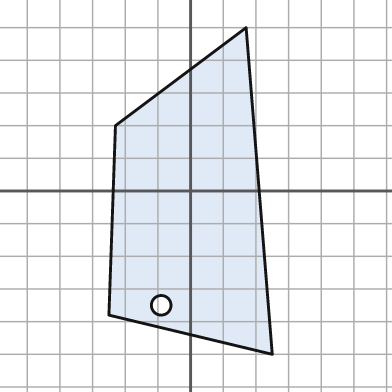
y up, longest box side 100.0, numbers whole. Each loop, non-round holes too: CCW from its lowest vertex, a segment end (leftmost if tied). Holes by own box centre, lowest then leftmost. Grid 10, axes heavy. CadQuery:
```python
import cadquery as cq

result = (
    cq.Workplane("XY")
    .moveTo(25.0, -50.0)
    .lineTo(17.0, 50.0)
    .lineTo(-23.0, 20.0)
    .lineTo(-25.0, -38.0)
    .close()
    .moveTo(-9.0, -35.0)
    .circle(3.0)
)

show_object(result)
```